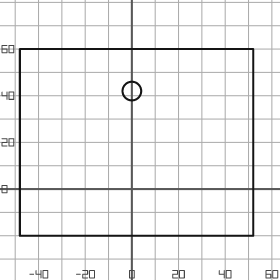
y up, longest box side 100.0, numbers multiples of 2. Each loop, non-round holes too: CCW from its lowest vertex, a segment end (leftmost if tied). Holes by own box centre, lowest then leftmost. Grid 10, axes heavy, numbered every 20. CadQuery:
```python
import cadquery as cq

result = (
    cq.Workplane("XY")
    .moveTo(-48.0, -20.0)
    .lineTo(52.0, -20.0)
    .lineTo(52.0, 60.0)
    .lineTo(-48.0, 60.0)
    .close()
    .moveTo(0.0, 42.0)
    .circle(4.0)
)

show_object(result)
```